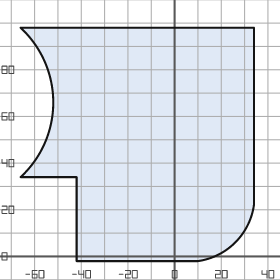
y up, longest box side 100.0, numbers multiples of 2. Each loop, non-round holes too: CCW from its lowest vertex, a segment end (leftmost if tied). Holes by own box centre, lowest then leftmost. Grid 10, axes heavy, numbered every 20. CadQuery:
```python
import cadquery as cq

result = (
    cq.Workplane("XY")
    .moveTo(-42.0, -2.0)
    .lineTo(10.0, -2.0)
    .threePointArc((26.0, 6.0), (34.0, 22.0))
    .lineTo(34.0, 98.0)
    .lineTo(-66.0, 98.0)
    .threePointArc((-52.0, 66.0), (-66.0, 34.0))
    .lineTo(-42.0, 34.0)
    .close()
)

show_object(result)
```